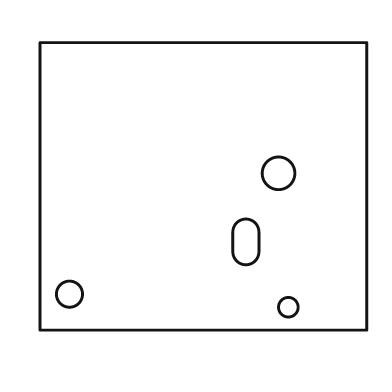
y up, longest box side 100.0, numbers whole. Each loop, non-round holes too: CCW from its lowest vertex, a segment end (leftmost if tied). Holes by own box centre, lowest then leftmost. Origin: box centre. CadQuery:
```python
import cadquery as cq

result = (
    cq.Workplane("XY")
    .moveTo(-50.0, -44.0)
    .lineTo(50.0, -44.0)
    .lineTo(50.0, 44.0)
    .lineTo(-50.0, 44.0)
    .close()
    .moveTo(26.0, -37.0)
    .circle(3.0)
    .moveTo(-41.0, -33.0)
    .circle(4.0)
    .moveTo(9.0, -20.0)
    .threePointArc((13.0, -24.0), (17.0, -20.0))
    .lineTo(17.0, -14.0)
    .threePointArc((13.0, -10.0), (9.0, -14.0))
    .close()
    .moveTo(23.0, 4.0)
    .circle(5.0)
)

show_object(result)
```